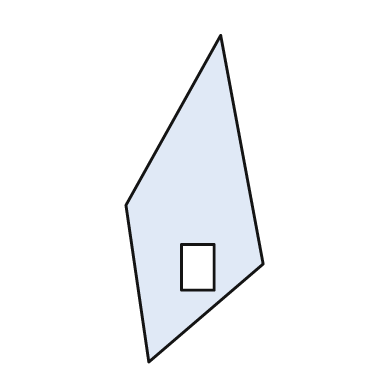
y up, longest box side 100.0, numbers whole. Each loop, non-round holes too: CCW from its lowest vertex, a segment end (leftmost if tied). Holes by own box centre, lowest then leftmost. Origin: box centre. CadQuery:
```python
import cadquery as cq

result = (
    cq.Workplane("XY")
    .moveTo(-14.0, -50.0)
    .lineTo(21.0, -20.0)
    .lineTo(8.0, 50.0)
    .lineTo(-21.0, -2.0)
    .close()
    .moveTo(-4.0, -28.0)
    .lineTo(6.0, -28.0)
    .lineTo(6.0, -14.0)
    .lineTo(-4.0, -14.0)
    .close()
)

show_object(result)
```